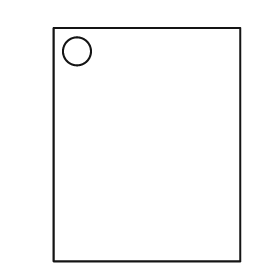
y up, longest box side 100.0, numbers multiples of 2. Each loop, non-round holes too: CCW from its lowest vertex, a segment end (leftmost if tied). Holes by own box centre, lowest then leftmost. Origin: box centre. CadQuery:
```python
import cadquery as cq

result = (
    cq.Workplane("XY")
    .moveTo(-40.0, -50.0)
    .lineTo(40.0, -50.0)
    .lineTo(40.0, 50.0)
    .lineTo(-40.0, 50.0)
    .close()
    .moveTo(-30.0, 40.0)
    .circle(6.0)
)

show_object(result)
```